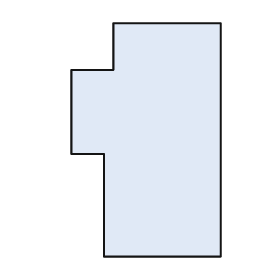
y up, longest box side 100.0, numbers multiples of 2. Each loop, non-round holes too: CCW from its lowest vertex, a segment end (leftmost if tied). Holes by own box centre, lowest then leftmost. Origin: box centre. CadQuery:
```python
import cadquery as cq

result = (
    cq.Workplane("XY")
    .moveTo(-18.0, -50.0)
    .lineTo(32.0, -50.0)
    .lineTo(32.0, 50.0)
    .lineTo(-14.0, 50.0)
    .lineTo(-14.0, 30.0)
    .lineTo(-32.0, 30.0)
    .lineTo(-32.0, -6.0)
    .lineTo(-18.0, -6.0)
    .close()
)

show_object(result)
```